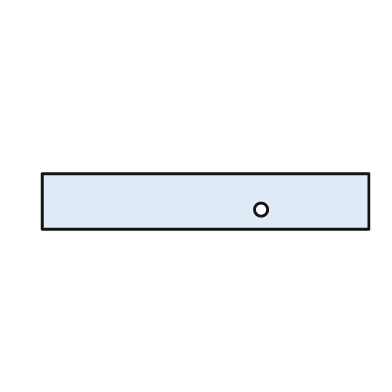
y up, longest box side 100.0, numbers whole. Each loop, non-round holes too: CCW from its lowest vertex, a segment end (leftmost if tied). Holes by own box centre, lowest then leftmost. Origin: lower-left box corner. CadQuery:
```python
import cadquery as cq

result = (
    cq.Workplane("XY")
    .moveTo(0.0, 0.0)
    .lineTo(100.0, 0.0)
    .lineTo(100.0, 17.0)
    .lineTo(0.0, 17.0)
    .close()
    .moveTo(67.0, 6.0)
    .circle(2.0)
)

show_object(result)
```